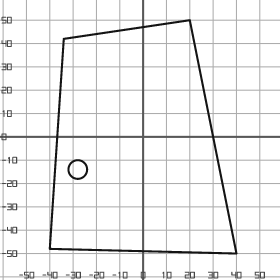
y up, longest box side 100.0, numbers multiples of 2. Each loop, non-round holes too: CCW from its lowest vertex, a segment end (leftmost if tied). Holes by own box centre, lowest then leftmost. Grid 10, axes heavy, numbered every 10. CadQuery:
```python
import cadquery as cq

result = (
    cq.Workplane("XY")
    .moveTo(40.0, -50.0)
    .lineTo(20.0, 50.0)
    .lineTo(-34.0, 42.0)
    .lineTo(-40.0, -48.0)
    .close()
    .moveTo(-28.0, -14.0)
    .circle(4.0)
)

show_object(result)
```